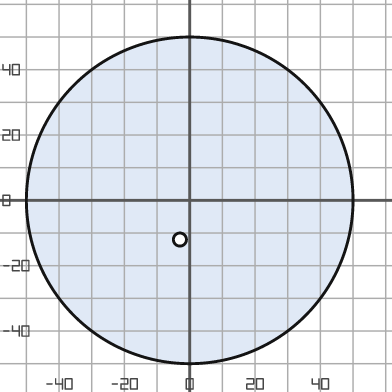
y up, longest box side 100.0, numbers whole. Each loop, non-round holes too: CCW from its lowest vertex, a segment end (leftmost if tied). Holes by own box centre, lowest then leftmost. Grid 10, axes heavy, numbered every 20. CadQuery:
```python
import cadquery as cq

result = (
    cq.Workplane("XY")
    .moveTo(0.0, 0.0)
    .circle(50.0)
    .moveTo(-3.0, -12.0)
    .circle(2.0)
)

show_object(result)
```